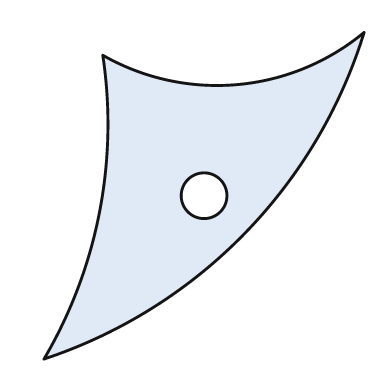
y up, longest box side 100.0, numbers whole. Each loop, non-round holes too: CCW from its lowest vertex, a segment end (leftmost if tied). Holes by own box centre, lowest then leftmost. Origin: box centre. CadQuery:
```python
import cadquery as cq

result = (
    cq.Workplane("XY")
    .moveTo(-49.0, -50.0)
    .threePointArc((12.0, -12.0), (49.0, 50.0))
    .threePointArc((10.0, 34.0), (-31.0, 43.0))
    .threePointArc((-32.0, -5.0), (-49.0, -50.0))
    .close()
    .moveTo(0.0, 0.0)
    .circle(7.0)
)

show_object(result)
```